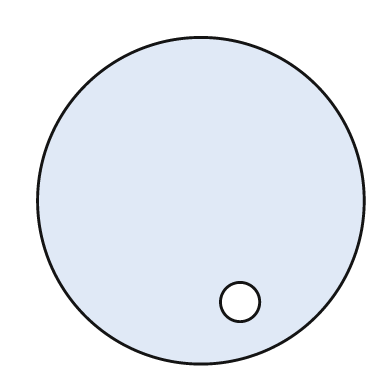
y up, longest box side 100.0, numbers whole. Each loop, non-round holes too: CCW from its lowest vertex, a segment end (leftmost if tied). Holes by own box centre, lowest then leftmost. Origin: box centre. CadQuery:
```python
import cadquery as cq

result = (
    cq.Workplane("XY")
    .moveTo(0.0, 0.0)
    .circle(50.0)
    .moveTo(12.0, -31.0)
    .circle(6.0)
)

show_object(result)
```